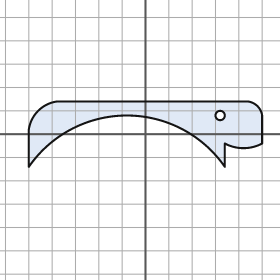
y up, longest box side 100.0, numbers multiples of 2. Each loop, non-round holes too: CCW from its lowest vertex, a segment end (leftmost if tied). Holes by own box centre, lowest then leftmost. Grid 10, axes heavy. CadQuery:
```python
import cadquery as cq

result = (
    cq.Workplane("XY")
    .moveTo(-50.0, -14.0)
    .threePointArc((-8.0, 8.0), (34.0, -14.0))
    .lineTo(34.0, -4.0)
    .threePointArc((42.0, -6.0), (50.0, -4.0))
    .lineTo(50.0, 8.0)
    .threePointArc((48.0, 12.0), (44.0, 14.0))
    .lineTo(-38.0, 14.0)
    .threePointArc((-46.0, 10.0), (-50.0, 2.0))
    .close()
    .moveTo(32.0, 8.0)
    .circle(2.0)
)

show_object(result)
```